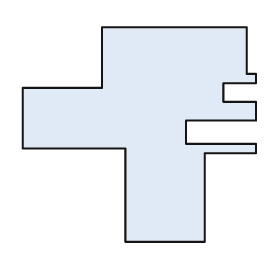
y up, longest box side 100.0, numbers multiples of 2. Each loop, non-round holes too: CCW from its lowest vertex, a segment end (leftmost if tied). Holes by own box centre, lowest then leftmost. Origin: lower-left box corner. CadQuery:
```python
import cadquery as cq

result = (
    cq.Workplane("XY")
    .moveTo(44.0, 0.0)
    .lineTo(78.0, 0.0)
    .lineTo(78.0, 38.0)
    .lineTo(100.0, 38.0)
    .lineTo(100.0, 42.0)
    .lineTo(70.0, 42.0)
    .lineTo(70.0, 52.0)
    .lineTo(100.0, 52.0)
    .lineTo(100.0, 60.0)
    .lineTo(86.0, 60.0)
    .lineTo(86.0, 68.0)
    .lineTo(100.0, 68.0)
    .lineTo(100.0, 72.0)
    .lineTo(96.0, 72.0)
    .lineTo(96.0, 92.0)
    .lineTo(34.0, 92.0)
    .lineTo(34.0, 66.0)
    .lineTo(0.0, 66.0)
    .lineTo(0.0, 40.0)
    .lineTo(44.0, 40.0)
    .close()
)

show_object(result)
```